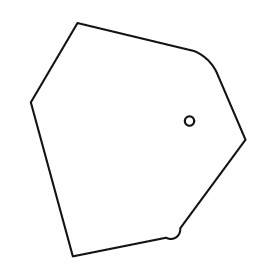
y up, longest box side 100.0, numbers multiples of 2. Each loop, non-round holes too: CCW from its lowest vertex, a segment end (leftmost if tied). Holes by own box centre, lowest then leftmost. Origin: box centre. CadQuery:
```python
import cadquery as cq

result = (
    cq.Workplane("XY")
    .moveTo(-28.0, -50.0)
    .lineTo(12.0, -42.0)
    .threePointArc((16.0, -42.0), (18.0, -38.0))
    .lineTo(46.0, 0.0)
    .lineTo(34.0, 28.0)
    .threePointArc((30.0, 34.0), (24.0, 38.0))
    .lineTo(-26.0, 50.0)
    .lineTo(-46.0, 16.0)
    .close()
    .moveTo(22.0, 8.0)
    .circle(2.0)
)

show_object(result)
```